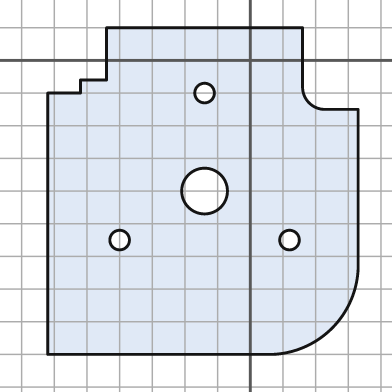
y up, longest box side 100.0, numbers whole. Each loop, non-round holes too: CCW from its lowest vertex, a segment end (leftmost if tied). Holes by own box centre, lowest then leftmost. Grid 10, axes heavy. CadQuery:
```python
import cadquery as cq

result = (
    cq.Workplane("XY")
    .moveTo(-62.0, -90.0)
    .lineTo(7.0, -90.0)
    .threePointArc((25.0, -82.0), (33.0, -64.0))
    .lineTo(33.0, -15.0)
    .lineTo(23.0, -15.0)
    .threePointArc((18.0, -13.0), (16.0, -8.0))
    .lineTo(16.0, 10.0)
    .lineTo(-44.0, 10.0)
    .lineTo(-44.0, -6.0)
    .lineTo(-52.0, -6.0)
    .lineTo(-52.0, -10.0)
    .lineTo(-62.0, -10.0)
    .close()
    .moveTo(-40.0, -55.0)
    .circle(3.0)
    .moveTo(12.0, -55.0)
    .circle(3.0)
    .moveTo(-14.0, -40.0)
    .circle(7.0)
    .moveTo(-14.0, -10.0)
    .circle(3.0)
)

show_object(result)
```